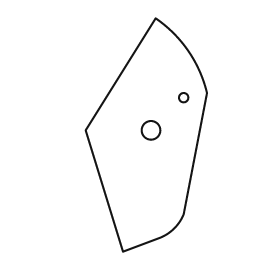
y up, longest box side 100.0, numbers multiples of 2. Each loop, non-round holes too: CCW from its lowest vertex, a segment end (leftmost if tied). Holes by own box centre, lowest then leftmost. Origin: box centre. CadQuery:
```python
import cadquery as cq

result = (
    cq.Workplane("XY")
    .moveTo(-10.0, -50.0)
    .lineTo(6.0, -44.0)
    .threePointArc((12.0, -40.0), (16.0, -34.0))
    .lineTo(26.0, 18.0)
    .threePointArc((18.0, 36.0), (4.0, 50.0))
    .lineTo(-26.0, 2.0)
    .close()
    .moveTo(2.0, 2.0)
    .circle(4.0)
    .moveTo(16.0, 16.0)
    .circle(2.0)
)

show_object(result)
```